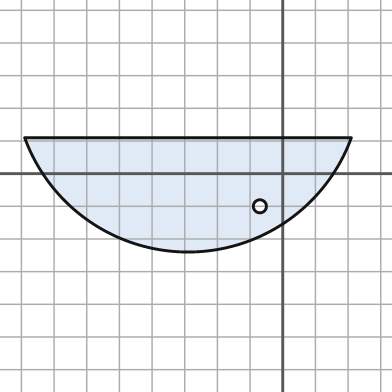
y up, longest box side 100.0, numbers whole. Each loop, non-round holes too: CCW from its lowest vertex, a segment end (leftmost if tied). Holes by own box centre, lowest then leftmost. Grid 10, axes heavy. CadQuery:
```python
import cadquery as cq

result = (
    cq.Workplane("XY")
    .moveTo(-79.0, 11.0)
    .threePointArc((-29.0, -24.0), (21.0, 11.0))
    .close()
    .moveTo(-7.0, -10.0)
    .circle(2.0)
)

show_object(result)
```